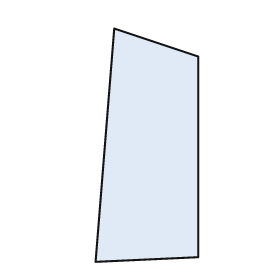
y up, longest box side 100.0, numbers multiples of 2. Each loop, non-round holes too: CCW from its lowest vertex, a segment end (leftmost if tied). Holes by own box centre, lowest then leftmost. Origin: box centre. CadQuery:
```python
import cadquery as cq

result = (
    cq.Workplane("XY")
    .moveTo(-22.0, -50.0)
    .lineTo(22.0, -48.0)
    .lineTo(22.0, 38.0)
    .lineTo(-14.0, 50.0)
    .close()
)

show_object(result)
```